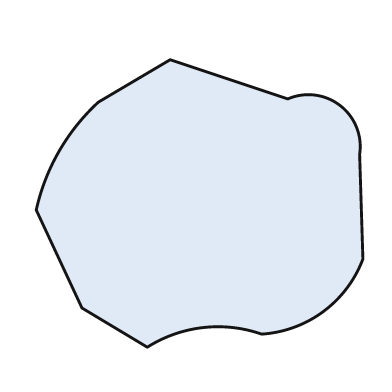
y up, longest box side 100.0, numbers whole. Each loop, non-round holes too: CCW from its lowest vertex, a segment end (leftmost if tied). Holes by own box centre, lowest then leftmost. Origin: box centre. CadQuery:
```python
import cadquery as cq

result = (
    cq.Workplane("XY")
    .moveTo(-16.0, -44.0)
    .threePointArc((1.0, -38.0), (19.0, -40.0))
    .threePointArc((38.0, -33.0), (50.0, -17.0))
    .lineTo(49.0, 15.0)
    .threePointArc((43.0, 30.0), (27.0, 32.0))
    .lineTo(-9.0, 44.0)
    .lineTo(-31.0, 31.0)
    .threePointArc((-43.0, 16.0), (-50.0, -2.0))
    .lineTo(-36.0, -32.0)
    .close()
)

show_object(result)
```